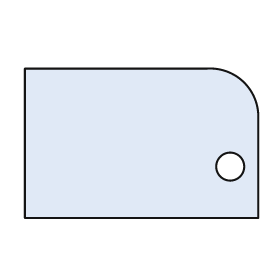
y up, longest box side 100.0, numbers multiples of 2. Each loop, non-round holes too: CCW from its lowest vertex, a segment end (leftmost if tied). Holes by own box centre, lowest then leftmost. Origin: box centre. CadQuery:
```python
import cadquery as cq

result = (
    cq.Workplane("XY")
    .moveTo(-50.0, -32.0)
    .lineTo(50.0, -32.0)
    .lineTo(50.0, 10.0)
    .threePointArc((44.0, 26.0), (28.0, 32.0))
    .lineTo(-50.0, 32.0)
    .close()
    .moveTo(38.0, -10.0)
    .circle(6.0)
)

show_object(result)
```